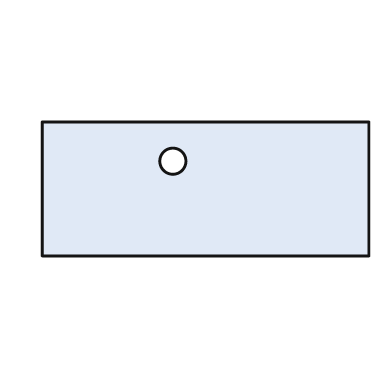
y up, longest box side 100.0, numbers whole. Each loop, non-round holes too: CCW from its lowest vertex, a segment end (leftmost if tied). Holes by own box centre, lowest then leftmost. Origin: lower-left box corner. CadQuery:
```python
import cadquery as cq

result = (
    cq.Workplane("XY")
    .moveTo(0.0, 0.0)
    .lineTo(100.0, 0.0)
    .lineTo(100.0, 41.0)
    .lineTo(0.0, 41.0)
    .close()
    .moveTo(40.0, 29.0)
    .circle(4.0)
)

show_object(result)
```